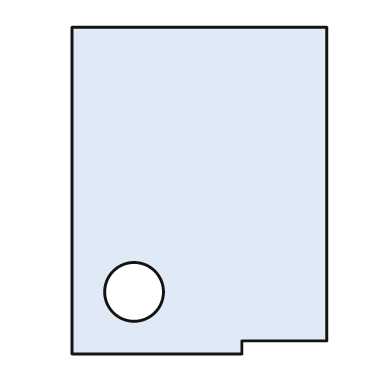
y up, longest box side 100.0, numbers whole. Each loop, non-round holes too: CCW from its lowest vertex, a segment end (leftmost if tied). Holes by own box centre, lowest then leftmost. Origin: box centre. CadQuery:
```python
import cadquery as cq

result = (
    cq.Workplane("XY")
    .moveTo(-39.0, -50.0)
    .lineTo(13.0, -50.0)
    .lineTo(13.0, -46.0)
    .lineTo(39.0, -46.0)
    .lineTo(39.0, 50.0)
    .lineTo(-39.0, 50.0)
    .close()
    .moveTo(-20.0, -31.0)
    .circle(9.0)
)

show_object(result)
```